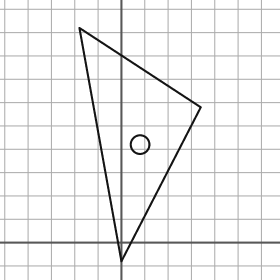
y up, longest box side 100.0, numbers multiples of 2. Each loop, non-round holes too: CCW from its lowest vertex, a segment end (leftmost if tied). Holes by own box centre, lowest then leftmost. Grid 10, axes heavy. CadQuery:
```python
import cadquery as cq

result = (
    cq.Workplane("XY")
    .moveTo(0.0, -8.0)
    .lineTo(34.0, 58.0)
    .lineTo(-18.0, 92.0)
    .close()
    .moveTo(8.0, 42.0)
    .circle(4.0)
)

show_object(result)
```